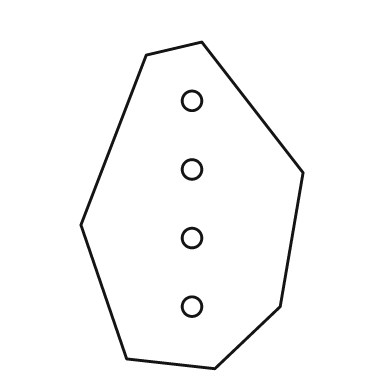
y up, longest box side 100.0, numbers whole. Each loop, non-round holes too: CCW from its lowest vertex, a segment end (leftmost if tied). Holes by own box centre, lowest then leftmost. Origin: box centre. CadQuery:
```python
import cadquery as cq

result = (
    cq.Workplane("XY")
    .moveTo(7.0, -50.0)
    .lineTo(27.0, -31.0)
    .lineTo(34.0, 10.0)
    .lineTo(3.0, 50.0)
    .lineTo(-14.0, 46.0)
    .lineTo(-34.0, -6.0)
    .lineTo(-20.0, -47.0)
    .close()
    .moveTo(0.0, -31.0)
    .circle(3.0)
    .moveTo(0.0, -10.0)
    .circle(3.0)
    .moveTo(0.0, 11.0)
    .circle(3.0)
    .moveTo(0.0, 32.0)
    .circle(3.0)
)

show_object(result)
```